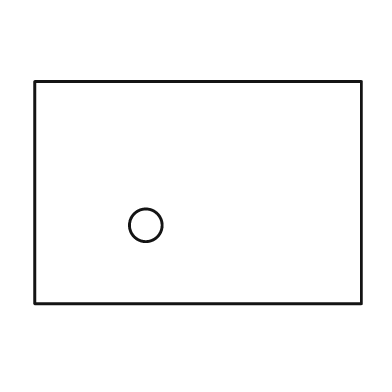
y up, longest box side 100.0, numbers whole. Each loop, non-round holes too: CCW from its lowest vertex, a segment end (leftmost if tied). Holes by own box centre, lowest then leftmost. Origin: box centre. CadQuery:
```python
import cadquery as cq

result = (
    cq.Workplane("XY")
    .moveTo(-50.0, -34.0)
    .lineTo(50.0, -34.0)
    .lineTo(50.0, 34.0)
    .lineTo(-50.0, 34.0)
    .close()
    .moveTo(-16.0, -10.0)
    .circle(5.0)
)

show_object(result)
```